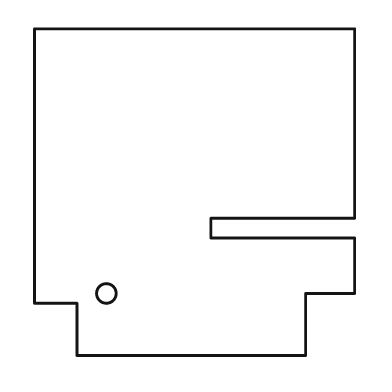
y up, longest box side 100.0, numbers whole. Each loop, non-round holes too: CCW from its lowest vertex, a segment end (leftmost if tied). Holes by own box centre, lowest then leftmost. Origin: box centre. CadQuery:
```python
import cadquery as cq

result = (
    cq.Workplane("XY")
    .moveTo(-36.0, -50.0)
    .lineTo(34.0, -50.0)
    .lineTo(34.0, -31.0)
    .lineTo(49.0, -31.0)
    .lineTo(49.0, -14.0)
    .lineTo(5.0, -14.0)
    .lineTo(5.0, -8.0)
    .lineTo(49.0, -8.0)
    .lineTo(49.0, 50.0)
    .lineTo(-49.0, 50.0)
    .lineTo(-49.0, -34.0)
    .lineTo(-36.0, -34.0)
    .close()
    .moveTo(-27.0, -31.0)
    .circle(3.0)
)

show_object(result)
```